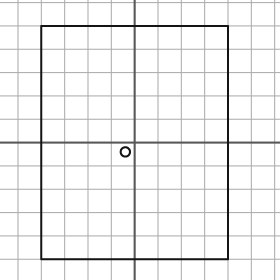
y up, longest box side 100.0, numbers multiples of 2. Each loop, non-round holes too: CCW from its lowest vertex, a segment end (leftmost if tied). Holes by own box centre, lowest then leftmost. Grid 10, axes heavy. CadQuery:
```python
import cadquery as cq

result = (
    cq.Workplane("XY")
    .moveTo(-40.0, -50.0)
    .lineTo(40.0, -50.0)
    .lineTo(40.0, 50.0)
    .lineTo(-40.0, 50.0)
    .close()
    .moveTo(-4.0, -4.0)
    .circle(2.0)
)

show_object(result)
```